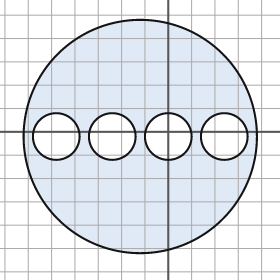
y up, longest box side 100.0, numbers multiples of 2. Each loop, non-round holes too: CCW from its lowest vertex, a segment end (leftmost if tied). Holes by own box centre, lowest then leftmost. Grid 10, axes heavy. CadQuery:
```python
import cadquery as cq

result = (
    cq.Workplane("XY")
    .moveTo(-12.0, -2.0)
    .circle(50.0)
    .moveTo(-48.0, -2.0)
    .circle(10.0)
    .moveTo(-24.0, -2.0)
    .circle(10.0)
    .moveTo(0.0, -2.0)
    .circle(10.0)
    .moveTo(24.0, -2.0)
    .circle(10.0)
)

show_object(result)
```